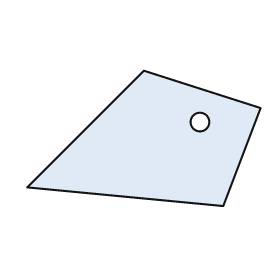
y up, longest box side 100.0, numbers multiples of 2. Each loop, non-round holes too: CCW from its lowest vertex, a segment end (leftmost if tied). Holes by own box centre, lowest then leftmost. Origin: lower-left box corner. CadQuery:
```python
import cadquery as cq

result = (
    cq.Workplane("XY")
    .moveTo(84.0, 0.0)
    .lineTo(100.0, 42.0)
    .lineTo(50.0, 58.0)
    .lineTo(0.0, 8.0)
    .close()
    .moveTo(74.0, 36.0)
    .circle(4.0)
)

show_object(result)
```